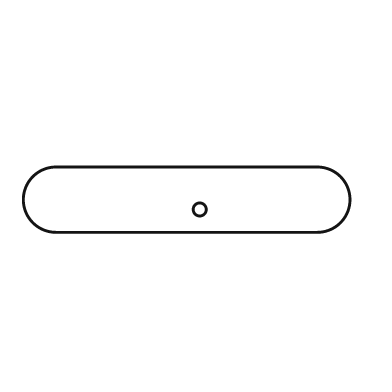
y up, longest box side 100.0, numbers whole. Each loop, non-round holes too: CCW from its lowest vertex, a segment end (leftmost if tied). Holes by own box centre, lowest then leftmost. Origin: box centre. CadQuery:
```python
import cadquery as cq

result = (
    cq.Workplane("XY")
    .moveTo(-40.0, -10.0)
    .lineTo(40.0, -10.0)
    .threePointArc((50.0, 0.0), (40.0, 10.0))
    .lineTo(-40.0, 10.0)
    .threePointArc((-50.0, 0.0), (-40.0, -10.0))
    .close()
    .moveTo(4.0, -3.0)
    .circle(2.0)
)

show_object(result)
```